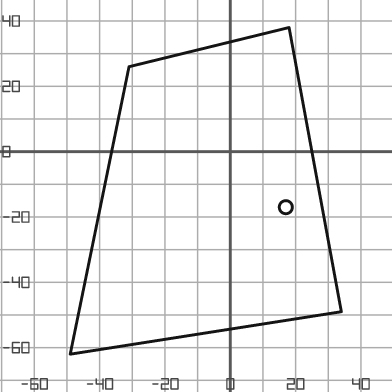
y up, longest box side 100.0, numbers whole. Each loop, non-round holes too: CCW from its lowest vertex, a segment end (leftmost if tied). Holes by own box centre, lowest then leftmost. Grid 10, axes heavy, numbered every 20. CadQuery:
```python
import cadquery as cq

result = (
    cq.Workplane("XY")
    .moveTo(-49.0, -62.0)
    .lineTo(34.0, -49.0)
    .lineTo(18.0, 38.0)
    .lineTo(-31.0, 26.0)
    .close()
    .moveTo(17.0, -17.0)
    .circle(2.0)
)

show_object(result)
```